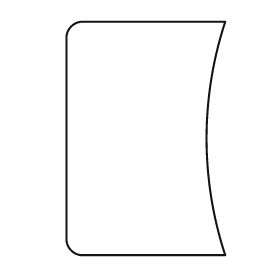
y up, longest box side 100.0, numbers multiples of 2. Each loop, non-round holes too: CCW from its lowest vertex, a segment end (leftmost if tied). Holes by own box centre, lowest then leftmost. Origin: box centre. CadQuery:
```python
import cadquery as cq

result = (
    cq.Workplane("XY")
    .moveTo(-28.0, -50.0)
    .lineTo(34.0, -50.0)
    .threePointArc((26.0, 0.0), (34.0, 50.0))
    .lineTo(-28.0, 50.0)
    .threePointArc((-32.0, 48.0), (-34.0, 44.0))
    .lineTo(-34.0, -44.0)
    .threePointArc((-32.0, -48.0), (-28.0, -50.0))
    .close()
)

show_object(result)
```